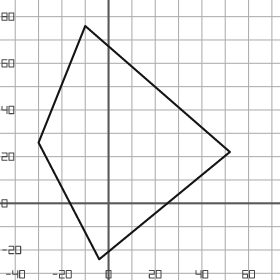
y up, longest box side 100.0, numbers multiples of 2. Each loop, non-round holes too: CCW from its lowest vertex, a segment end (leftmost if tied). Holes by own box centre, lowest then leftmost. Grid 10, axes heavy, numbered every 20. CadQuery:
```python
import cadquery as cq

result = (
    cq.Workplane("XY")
    .moveTo(-4.0, -24.0)
    .lineTo(52.0, 22.0)
    .lineTo(-10.0, 76.0)
    .lineTo(-30.0, 26.0)
    .close()
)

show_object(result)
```